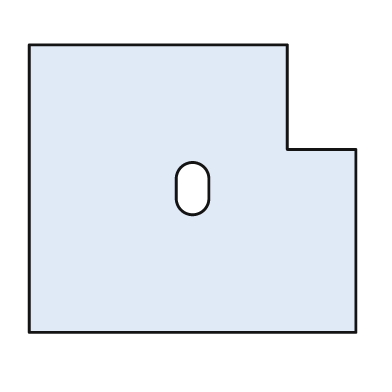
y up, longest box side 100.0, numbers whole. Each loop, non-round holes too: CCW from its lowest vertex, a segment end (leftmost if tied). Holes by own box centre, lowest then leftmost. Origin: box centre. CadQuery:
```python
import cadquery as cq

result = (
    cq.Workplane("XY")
    .moveTo(-50.0, -44.0)
    .lineTo(50.0, -44.0)
    .lineTo(50.0, 12.0)
    .lineTo(29.0, 12.0)
    .lineTo(29.0, 44.0)
    .lineTo(-50.0, 44.0)
    .close()
    .moveTo(-5.0, -3.0)
    .threePointArc((0.0, -8.0), (5.0, -3.0))
    .lineTo(5.0, 3.0)
    .threePointArc((0.0, 8.0), (-5.0, 3.0))
    .close()
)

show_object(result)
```